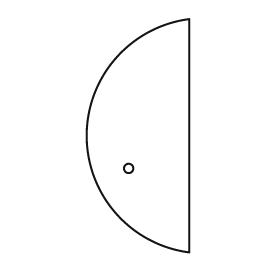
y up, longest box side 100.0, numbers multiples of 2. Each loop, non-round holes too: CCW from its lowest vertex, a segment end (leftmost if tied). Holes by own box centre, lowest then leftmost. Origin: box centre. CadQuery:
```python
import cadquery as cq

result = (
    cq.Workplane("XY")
    .moveTo(22.0, -50.0)
    .lineTo(22.0, 50.0)
    .threePointArc((-22.0, 0.0), (22.0, -50.0))
    .close()
    .moveTo(-4.0, -14.0)
    .circle(2.0)
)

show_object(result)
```